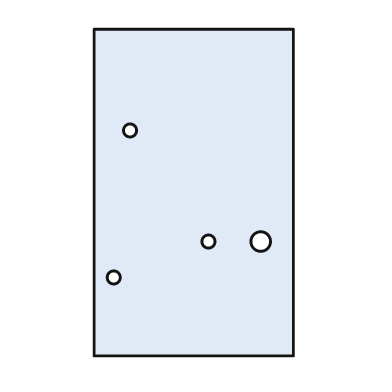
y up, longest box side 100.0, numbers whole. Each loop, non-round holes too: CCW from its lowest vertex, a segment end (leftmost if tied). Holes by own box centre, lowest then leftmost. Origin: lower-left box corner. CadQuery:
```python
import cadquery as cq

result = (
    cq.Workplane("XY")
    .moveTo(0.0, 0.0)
    .lineTo(61.0, 0.0)
    .lineTo(61.0, 100.0)
    .lineTo(0.0, 100.0)
    .close()
    .moveTo(6.0, 24.0)
    .circle(2.0)
    .moveTo(35.0, 35.0)
    .circle(2.0)
    .moveTo(51.0, 35.0)
    .circle(3.0)
    .moveTo(11.0, 69.0)
    .circle(2.0)
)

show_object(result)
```